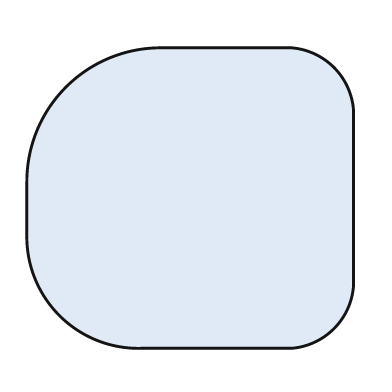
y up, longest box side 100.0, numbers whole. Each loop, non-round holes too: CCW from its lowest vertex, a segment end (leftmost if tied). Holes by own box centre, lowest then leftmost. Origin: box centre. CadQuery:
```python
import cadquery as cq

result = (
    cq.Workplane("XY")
    .moveTo(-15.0, -46.0)
    .lineTo(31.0, -46.0)
    .threePointArc((44.0, -40.0), (50.0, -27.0))
    .lineTo(50.0, 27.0)
    .threePointArc((44.0, 40.0), (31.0, 46.0))
    .lineTo(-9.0, 46.0)
    .threePointArc((-38.0, 34.0), (-50.0, 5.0))
    .lineTo(-50.0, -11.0)
    .threePointArc((-40.0, -36.0), (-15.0, -46.0))
    .close()
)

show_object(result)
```